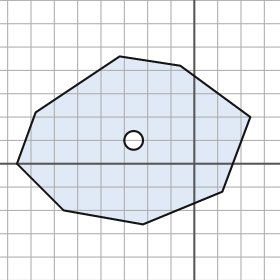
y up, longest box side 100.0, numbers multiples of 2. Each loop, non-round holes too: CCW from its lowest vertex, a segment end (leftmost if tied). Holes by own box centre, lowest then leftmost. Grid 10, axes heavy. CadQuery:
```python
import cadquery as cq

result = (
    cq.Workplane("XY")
    .moveTo(-22.0, -26.0)
    .lineTo(12.0, -12.0)
    .lineTo(24.0, 20.0)
    .lineTo(-6.0, 42.0)
    .lineTo(-32.0, 46.0)
    .lineTo(-68.0, 22.0)
    .lineTo(-76.0, 0.0)
    .lineTo(-56.0, -20.0)
    .close()
    .moveTo(-26.0, 10.0)
    .circle(4.0)
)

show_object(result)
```